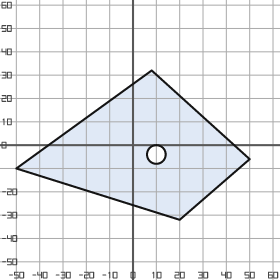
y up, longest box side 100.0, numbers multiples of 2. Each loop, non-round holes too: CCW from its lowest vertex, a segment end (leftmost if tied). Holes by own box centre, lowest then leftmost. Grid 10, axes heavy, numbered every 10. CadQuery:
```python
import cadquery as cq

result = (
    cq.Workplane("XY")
    .moveTo(20.0, -32.0)
    .lineTo(50.0, -6.0)
    .lineTo(8.0, 32.0)
    .lineTo(-50.0, -10.0)
    .close()
    .moveTo(10.0, -4.0)
    .circle(4.0)
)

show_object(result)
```